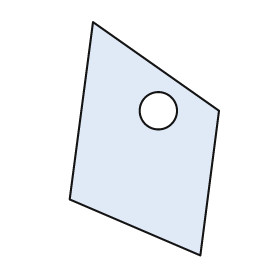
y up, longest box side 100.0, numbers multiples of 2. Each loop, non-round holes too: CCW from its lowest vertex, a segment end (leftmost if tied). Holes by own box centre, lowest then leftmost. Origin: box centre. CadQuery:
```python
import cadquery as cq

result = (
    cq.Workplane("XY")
    .moveTo(24.0, -50.0)
    .lineTo(32.0, 12.0)
    .lineTo(-22.0, 50.0)
    .lineTo(-32.0, -26.0)
    .close()
    .moveTo(6.0, 12.0)
    .circle(8.0)
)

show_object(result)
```